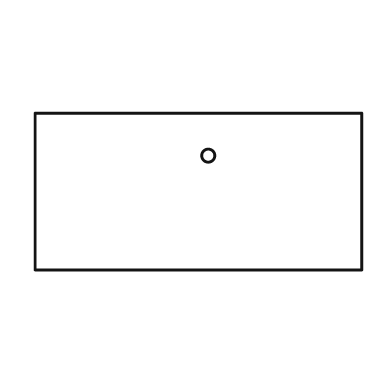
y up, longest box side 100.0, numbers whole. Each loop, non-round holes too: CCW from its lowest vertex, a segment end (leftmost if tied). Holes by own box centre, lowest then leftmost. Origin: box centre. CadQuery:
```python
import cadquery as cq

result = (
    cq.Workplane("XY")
    .moveTo(-50.0, -24.0)
    .lineTo(50.0, -24.0)
    .lineTo(50.0, 24.0)
    .lineTo(-50.0, 24.0)
    .close()
    .moveTo(3.0, 11.0)
    .circle(2.0)
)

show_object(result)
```